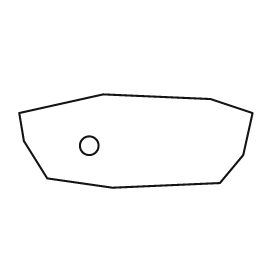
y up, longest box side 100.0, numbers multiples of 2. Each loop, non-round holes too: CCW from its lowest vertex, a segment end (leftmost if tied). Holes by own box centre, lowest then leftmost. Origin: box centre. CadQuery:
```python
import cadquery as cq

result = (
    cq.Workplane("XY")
    .moveTo(-10.0, -20.0)
    .lineTo(36.0, -18.0)
    .lineTo(46.0, -6.0)
    .lineTo(50.0, 12.0)
    .lineTo(32.0, 18.0)
    .lineTo(-14.0, 20.0)
    .lineTo(-50.0, 12.0)
    .lineTo(-48.0, 0.0)
    .lineTo(-38.0, -16.0)
    .close()
    .moveTo(-20.0, -2.0)
    .circle(4.0)
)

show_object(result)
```